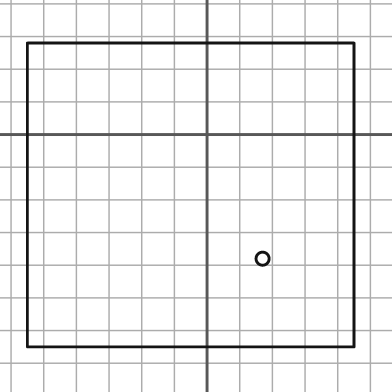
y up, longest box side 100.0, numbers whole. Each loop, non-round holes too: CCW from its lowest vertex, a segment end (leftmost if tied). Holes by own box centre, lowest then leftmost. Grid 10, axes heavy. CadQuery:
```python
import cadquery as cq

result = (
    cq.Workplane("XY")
    .moveTo(-55.0, -65.0)
    .lineTo(45.0, -65.0)
    .lineTo(45.0, 28.0)
    .lineTo(-55.0, 28.0)
    .close()
    .moveTo(17.0, -38.0)
    .circle(2.0)
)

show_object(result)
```